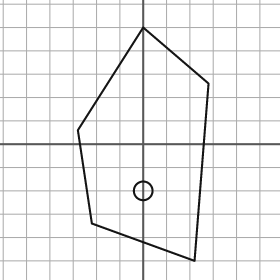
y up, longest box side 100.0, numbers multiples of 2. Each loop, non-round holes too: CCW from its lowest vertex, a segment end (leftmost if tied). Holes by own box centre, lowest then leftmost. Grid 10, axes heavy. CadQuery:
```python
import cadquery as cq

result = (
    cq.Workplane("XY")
    .moveTo(22.0, -50.0)
    .lineTo(28.0, 26.0)
    .lineTo(0.0, 50.0)
    .lineTo(-28.0, 6.0)
    .lineTo(-22.0, -34.0)
    .close()
    .moveTo(0.0, -20.0)
    .circle(4.0)
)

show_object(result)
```